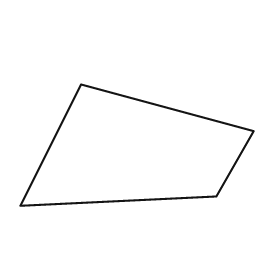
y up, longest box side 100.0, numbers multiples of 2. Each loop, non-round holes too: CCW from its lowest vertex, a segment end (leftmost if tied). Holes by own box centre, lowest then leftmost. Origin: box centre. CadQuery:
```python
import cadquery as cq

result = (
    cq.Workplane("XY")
    .moveTo(-50.0, -26.0)
    .lineTo(34.0, -22.0)
    .lineTo(50.0, 6.0)
    .lineTo(-24.0, 26.0)
    .close()
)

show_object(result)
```